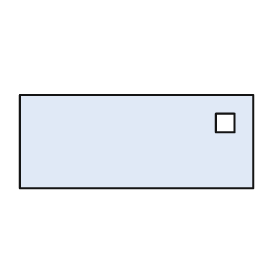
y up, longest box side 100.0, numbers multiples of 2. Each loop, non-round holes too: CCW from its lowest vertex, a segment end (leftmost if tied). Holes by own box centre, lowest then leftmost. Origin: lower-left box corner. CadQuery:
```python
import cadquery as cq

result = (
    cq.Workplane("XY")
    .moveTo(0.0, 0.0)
    .lineTo(100.0, 0.0)
    .lineTo(100.0, 40.0)
    .lineTo(0.0, 40.0)
    .close()
    .moveTo(84.0, 24.0)
    .lineTo(92.0, 24.0)
    .lineTo(92.0, 32.0)
    .lineTo(84.0, 32.0)
    .close()
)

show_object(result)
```